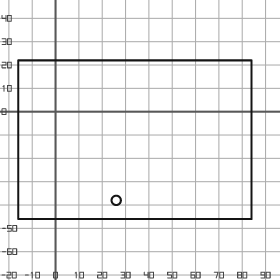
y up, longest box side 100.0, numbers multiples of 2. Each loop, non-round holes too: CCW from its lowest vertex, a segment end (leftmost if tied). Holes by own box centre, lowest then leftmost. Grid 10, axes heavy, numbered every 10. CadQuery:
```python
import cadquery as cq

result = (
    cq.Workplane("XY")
    .moveTo(-16.0, -46.0)
    .lineTo(84.0, -46.0)
    .lineTo(84.0, 22.0)
    .lineTo(-16.0, 22.0)
    .close()
    .moveTo(26.0, -38.0)
    .circle(2.0)
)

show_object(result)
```